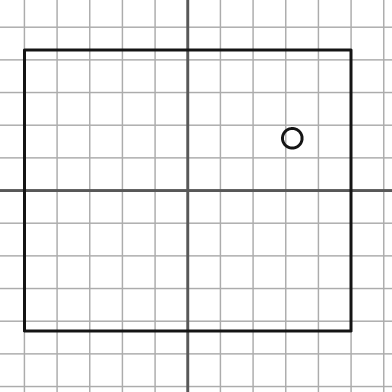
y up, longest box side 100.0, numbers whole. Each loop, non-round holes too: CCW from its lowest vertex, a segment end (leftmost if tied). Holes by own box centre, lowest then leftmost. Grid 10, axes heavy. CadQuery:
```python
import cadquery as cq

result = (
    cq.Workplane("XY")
    .moveTo(-50.0, -43.0)
    .lineTo(50.0, -43.0)
    .lineTo(50.0, 43.0)
    .lineTo(-50.0, 43.0)
    .close()
    .moveTo(32.0, 16.0)
    .circle(3.0)
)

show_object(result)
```